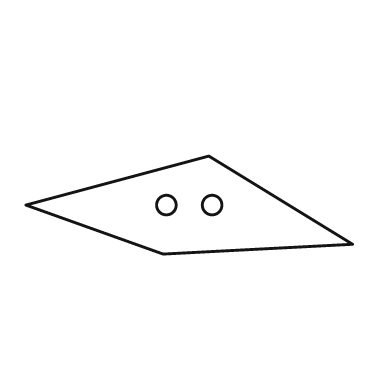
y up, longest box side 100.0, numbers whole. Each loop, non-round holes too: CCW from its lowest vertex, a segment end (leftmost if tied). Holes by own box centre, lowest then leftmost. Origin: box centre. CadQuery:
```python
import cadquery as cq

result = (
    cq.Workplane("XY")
    .moveTo(-8.0, -15.0)
    .lineTo(50.0, -12.0)
    .lineTo(6.0, 15.0)
    .lineTo(-50.0, 0.0)
    .close()
    .moveTo(-7.0, 0.0)
    .circle(3.0)
    .moveTo(7.0, 0.0)
    .circle(3.0)
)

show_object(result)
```